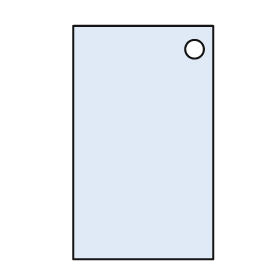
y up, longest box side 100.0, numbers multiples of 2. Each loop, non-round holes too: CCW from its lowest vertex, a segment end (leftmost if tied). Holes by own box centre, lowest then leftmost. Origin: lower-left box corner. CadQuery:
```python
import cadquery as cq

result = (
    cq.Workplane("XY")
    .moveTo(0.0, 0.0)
    .lineTo(60.0, 0.0)
    .lineTo(60.0, 100.0)
    .lineTo(0.0, 100.0)
    .close()
    .moveTo(52.0, 90.0)
    .circle(4.0)
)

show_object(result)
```